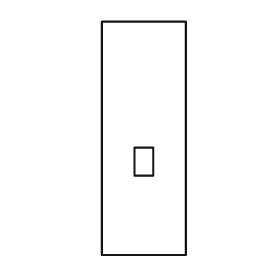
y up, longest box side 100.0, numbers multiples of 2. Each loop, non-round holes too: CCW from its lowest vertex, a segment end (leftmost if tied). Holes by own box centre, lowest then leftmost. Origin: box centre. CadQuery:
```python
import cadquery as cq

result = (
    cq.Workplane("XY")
    .moveTo(-18.0, -50.0)
    .lineTo(18.0, -50.0)
    .lineTo(18.0, 50.0)
    .lineTo(-18.0, 50.0)
    .close()
    .moveTo(-4.0, -16.0)
    .lineTo(4.0, -16.0)
    .lineTo(4.0, -4.0)
    .lineTo(-4.0, -4.0)
    .close()
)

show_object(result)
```